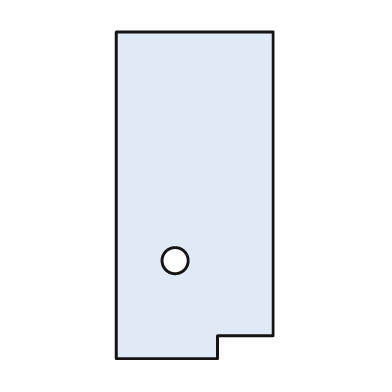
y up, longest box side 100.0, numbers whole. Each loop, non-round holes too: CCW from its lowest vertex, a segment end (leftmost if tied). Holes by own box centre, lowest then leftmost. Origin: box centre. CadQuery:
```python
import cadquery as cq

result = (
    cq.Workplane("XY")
    .moveTo(-24.0, -50.0)
    .lineTo(7.0, -50.0)
    .lineTo(7.0, -43.0)
    .lineTo(24.0, -43.0)
    .lineTo(24.0, 50.0)
    .lineTo(-24.0, 50.0)
    .close()
    .moveTo(-6.0, -20.0)
    .circle(4.0)
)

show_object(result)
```